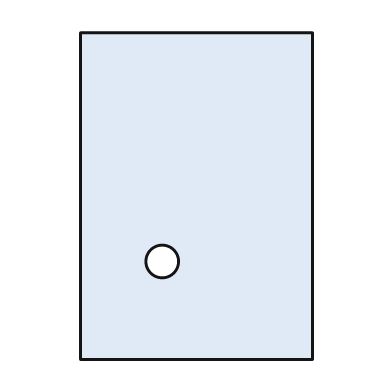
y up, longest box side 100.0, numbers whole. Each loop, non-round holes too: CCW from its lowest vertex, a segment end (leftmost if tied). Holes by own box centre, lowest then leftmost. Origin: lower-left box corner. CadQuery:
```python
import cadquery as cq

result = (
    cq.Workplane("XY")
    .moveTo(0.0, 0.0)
    .lineTo(71.0, 0.0)
    .lineTo(71.0, 100.0)
    .lineTo(0.0, 100.0)
    .close()
    .moveTo(25.0, 30.0)
    .circle(5.0)
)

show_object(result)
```